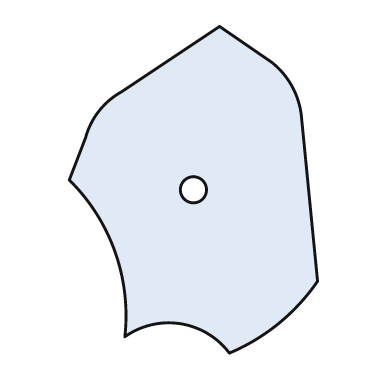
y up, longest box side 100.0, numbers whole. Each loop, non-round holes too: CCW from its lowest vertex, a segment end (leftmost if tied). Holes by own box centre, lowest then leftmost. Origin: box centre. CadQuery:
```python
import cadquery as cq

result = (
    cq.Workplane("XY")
    .moveTo(11.0, -50.0)
    .threePointArc((26.0, -41.0), (38.0, -28.0))
    .lineTo(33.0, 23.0)
    .threePointArc((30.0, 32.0), (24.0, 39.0))
    .lineTo(8.0, 50.0)
    .lineTo(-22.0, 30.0)
    .threePointArc((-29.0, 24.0), (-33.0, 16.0))
    .lineTo(-38.0, 3.0)
    .threePointArc((-24.0, -19.0), (-21.0, -45.0))
    .threePointArc((-4.0, -41.0), (11.0, -50.0))
    .close()
    .moveTo(0.0, 0.0)
    .circle(4.0)
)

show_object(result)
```